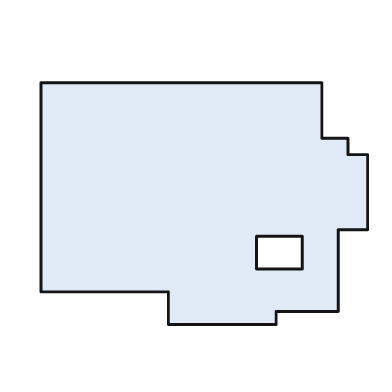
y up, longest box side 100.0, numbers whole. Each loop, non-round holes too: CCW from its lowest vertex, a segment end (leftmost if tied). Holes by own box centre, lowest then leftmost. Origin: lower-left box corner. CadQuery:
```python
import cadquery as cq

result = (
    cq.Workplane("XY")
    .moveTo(39.0, 0.0)
    .lineTo(72.0, 0.0)
    .lineTo(72.0, 4.0)
    .lineTo(91.0, 4.0)
    .lineTo(91.0, 29.0)
    .lineTo(100.0, 29.0)
    .lineTo(100.0, 52.0)
    .lineTo(94.0, 52.0)
    .lineTo(94.0, 57.0)
    .lineTo(86.0, 57.0)
    .lineTo(86.0, 74.0)
    .lineTo(0.0, 74.0)
    .lineTo(0.0, 10.0)
    .lineTo(39.0, 10.0)
    .close()
    .moveTo(66.0, 17.0)
    .lineTo(80.0, 17.0)
    .lineTo(80.0, 27.0)
    .lineTo(66.0, 27.0)
    .close()
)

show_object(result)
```